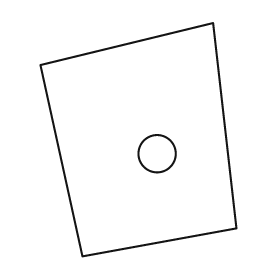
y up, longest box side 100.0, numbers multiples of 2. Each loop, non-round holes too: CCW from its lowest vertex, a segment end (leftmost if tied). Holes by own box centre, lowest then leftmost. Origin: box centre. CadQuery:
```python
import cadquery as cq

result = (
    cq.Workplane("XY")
    .moveTo(-24.0, -50.0)
    .lineTo(42.0, -38.0)
    .lineTo(32.0, 50.0)
    .lineTo(-42.0, 32.0)
    .close()
    .moveTo(8.0, -6.0)
    .circle(8.0)
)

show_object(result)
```